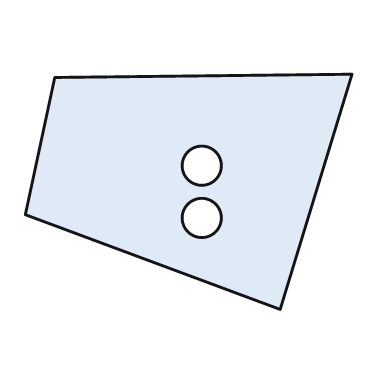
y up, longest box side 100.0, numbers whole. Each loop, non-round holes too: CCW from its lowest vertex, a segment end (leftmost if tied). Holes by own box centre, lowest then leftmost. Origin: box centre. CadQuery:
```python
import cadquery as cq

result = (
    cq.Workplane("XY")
    .moveTo(28.0, -36.0)
    .lineTo(50.0, 36.0)
    .lineTo(-41.0, 35.0)
    .lineTo(-50.0, -7.0)
    .close()
    .moveTo(4.0, -8.0)
    .circle(6.0)
    .moveTo(4.0, 8.0)
    .circle(6.0)
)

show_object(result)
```